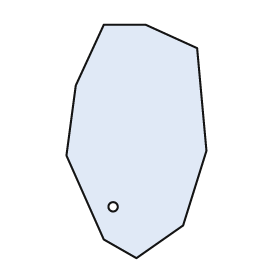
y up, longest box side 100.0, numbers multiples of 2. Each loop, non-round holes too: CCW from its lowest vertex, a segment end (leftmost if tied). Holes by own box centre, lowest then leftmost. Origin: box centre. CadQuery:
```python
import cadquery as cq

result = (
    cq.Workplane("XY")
    .moveTo(0.0, -50.0)
    .lineTo(20.0, -36.0)
    .lineTo(30.0, -4.0)
    .lineTo(26.0, 40.0)
    .lineTo(4.0, 50.0)
    .lineTo(-14.0, 50.0)
    .lineTo(-26.0, 24.0)
    .lineTo(-30.0, -6.0)
    .lineTo(-14.0, -42.0)
    .close()
    .moveTo(-10.0, -28.0)
    .circle(2.0)
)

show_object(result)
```